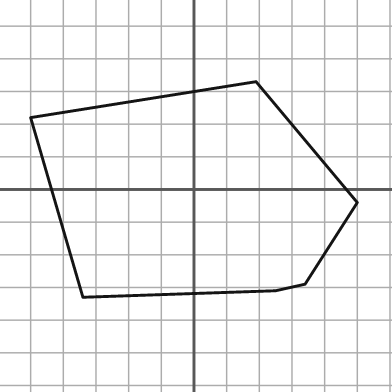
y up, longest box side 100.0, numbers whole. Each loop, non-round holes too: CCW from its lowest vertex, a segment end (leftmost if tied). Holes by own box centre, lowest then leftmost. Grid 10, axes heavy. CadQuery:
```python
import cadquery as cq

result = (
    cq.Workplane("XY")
    .moveTo(-34.0, -33.0)
    .lineTo(25.0, -31.0)
    .lineTo(34.0, -29.0)
    .lineTo(50.0, -4.0)
    .lineTo(19.0, 33.0)
    .lineTo(-50.0, 22.0)
    .close()
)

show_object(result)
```